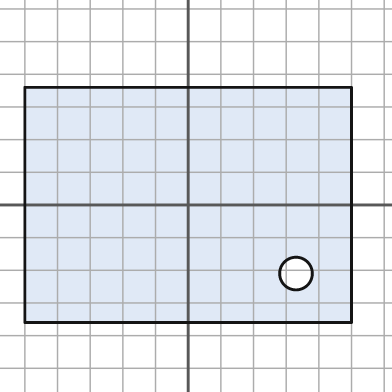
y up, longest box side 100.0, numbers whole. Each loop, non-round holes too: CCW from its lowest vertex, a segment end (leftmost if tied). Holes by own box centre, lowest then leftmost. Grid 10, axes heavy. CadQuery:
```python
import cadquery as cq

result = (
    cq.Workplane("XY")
    .moveTo(-50.0, -36.0)
    .lineTo(50.0, -36.0)
    .lineTo(50.0, 36.0)
    .lineTo(-50.0, 36.0)
    .close()
    .moveTo(33.0, -21.0)
    .circle(5.0)
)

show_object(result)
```